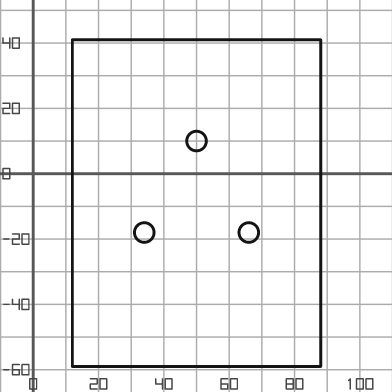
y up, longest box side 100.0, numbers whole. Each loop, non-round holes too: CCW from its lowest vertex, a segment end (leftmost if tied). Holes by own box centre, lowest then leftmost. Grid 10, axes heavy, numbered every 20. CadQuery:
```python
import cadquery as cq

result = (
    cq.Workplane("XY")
    .moveTo(12.0, -59.0)
    .lineTo(88.0, -59.0)
    .lineTo(88.0, 41.0)
    .lineTo(12.0, 41.0)
    .close()
    .moveTo(34.0, -18.0)
    .circle(3.0)
    .moveTo(66.0, -18.0)
    .circle(3.0)
    .moveTo(50.0, 10.0)
    .circle(3.0)
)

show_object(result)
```